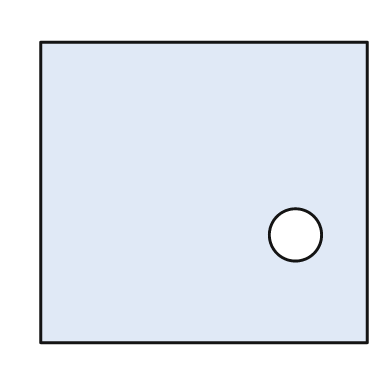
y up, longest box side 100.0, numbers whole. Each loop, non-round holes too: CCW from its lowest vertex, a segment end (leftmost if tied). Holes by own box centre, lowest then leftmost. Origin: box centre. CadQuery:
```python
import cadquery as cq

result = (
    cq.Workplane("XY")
    .moveTo(-50.0, -46.0)
    .lineTo(50.0, -46.0)
    .lineTo(50.0, 46.0)
    .lineTo(-50.0, 46.0)
    .close()
    .moveTo(28.0, -13.0)
    .circle(8.0)
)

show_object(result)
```